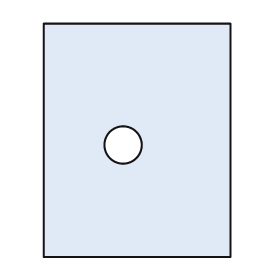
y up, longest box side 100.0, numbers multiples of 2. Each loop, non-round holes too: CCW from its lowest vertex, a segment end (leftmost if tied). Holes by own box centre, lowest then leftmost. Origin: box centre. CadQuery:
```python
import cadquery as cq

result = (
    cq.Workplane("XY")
    .moveTo(-40.0, -50.0)
    .lineTo(40.0, -50.0)
    .lineTo(40.0, 50.0)
    .lineTo(-40.0, 50.0)
    .close()
    .moveTo(-6.0, -2.0)
    .circle(8.0)
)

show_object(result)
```